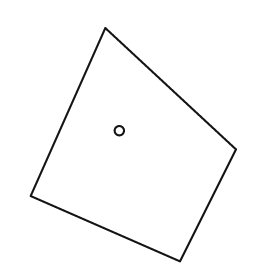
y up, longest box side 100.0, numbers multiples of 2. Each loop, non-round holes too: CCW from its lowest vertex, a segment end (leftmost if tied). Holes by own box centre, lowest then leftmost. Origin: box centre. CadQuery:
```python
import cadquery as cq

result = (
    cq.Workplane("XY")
    .moveTo(20.0, -50.0)
    .lineTo(44.0, -2.0)
    .lineTo(-12.0, 50.0)
    .lineTo(-44.0, -22.0)
    .close()
    .moveTo(-6.0, 6.0)
    .circle(2.0)
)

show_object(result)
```